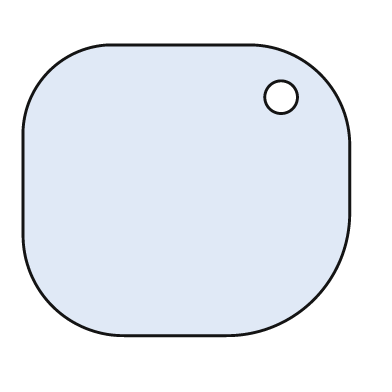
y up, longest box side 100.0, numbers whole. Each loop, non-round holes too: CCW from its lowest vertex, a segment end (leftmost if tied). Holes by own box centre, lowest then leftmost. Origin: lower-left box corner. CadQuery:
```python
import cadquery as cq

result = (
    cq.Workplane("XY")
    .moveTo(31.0, 0.0)
    .lineTo(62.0, 0.0)
    .threePointArc((89.0, 11.0), (100.0, 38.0))
    .lineTo(100.0, 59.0)
    .threePointArc((91.0, 80.0), (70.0, 89.0))
    .lineTo(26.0, 89.0)
    .threePointArc((8.0, 81.0), (0.0, 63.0))
    .lineTo(0.0, 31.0)
    .threePointArc((9.0, 9.0), (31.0, 0.0))
    .close()
    .moveTo(79.0, 73.0)
    .circle(5.0)
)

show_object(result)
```